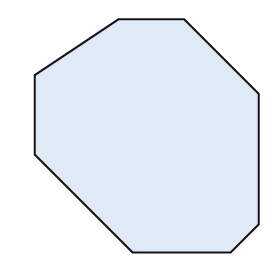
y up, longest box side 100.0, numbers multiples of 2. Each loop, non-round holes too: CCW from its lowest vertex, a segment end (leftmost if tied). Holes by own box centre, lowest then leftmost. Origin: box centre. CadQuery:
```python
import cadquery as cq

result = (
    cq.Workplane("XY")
    .moveTo(-6.0, -50.0)
    .lineTo(36.0, -50.0)
    .lineTo(48.0, -38.0)
    .lineTo(48.0, 18.0)
    .lineTo(16.0, 50.0)
    .lineTo(-12.0, 50.0)
    .lineTo(-48.0, 26.0)
    .lineTo(-48.0, -8.0)
    .close()
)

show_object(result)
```